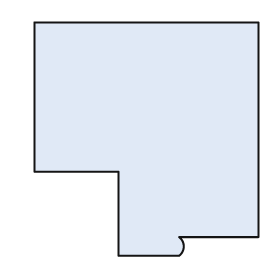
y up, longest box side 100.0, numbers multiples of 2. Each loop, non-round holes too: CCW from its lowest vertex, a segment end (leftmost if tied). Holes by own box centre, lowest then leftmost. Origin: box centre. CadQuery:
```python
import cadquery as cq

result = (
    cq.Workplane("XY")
    .moveTo(-12.0, -50.0)
    .lineTo(14.0, -50.0)
    .threePointArc((16.0, -46.0), (14.0, -42.0))
    .lineTo(48.0, -42.0)
    .lineTo(48.0, 50.0)
    .lineTo(-48.0, 50.0)
    .lineTo(-48.0, -14.0)
    .lineTo(-12.0, -14.0)
    .close()
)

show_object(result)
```